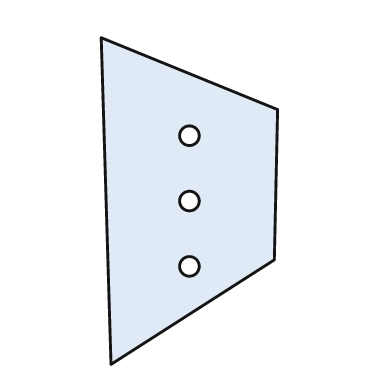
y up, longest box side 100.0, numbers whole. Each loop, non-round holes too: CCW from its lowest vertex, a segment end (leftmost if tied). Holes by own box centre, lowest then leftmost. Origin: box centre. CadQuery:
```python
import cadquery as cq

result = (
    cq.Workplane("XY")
    .moveTo(-24.0, -50.0)
    .lineTo(26.0, -18.0)
    .lineTo(27.0, 28.0)
    .lineTo(-27.0, 50.0)
    .close()
    .moveTo(0.0, -20.0)
    .circle(3.0)
    .moveTo(0.0, 0.0)
    .circle(3.0)
    .moveTo(0.0, 20.0)
    .circle(3.0)
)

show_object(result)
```